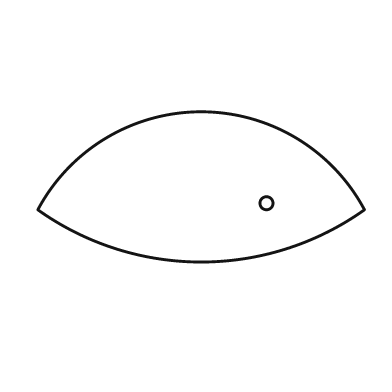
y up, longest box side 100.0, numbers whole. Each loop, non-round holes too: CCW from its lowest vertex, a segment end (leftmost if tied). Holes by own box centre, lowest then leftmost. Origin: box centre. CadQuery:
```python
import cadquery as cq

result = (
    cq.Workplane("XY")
    .moveTo(-50.0, -7.0)
    .threePointArc((0.0, -23.0), (50.0, -7.0))
    .threePointArc((0.0, 23.0), (-50.0, -7.0))
    .close()
    .moveTo(20.0, -5.0)
    .circle(2.0)
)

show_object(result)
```